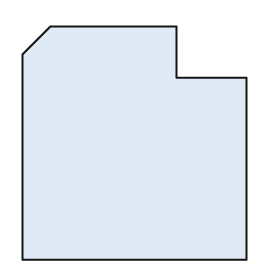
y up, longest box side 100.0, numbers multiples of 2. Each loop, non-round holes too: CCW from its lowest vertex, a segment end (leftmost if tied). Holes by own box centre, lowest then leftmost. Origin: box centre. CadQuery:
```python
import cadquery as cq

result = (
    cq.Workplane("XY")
    .moveTo(-48.0, -50.0)
    .lineTo(48.0, -50.0)
    .lineTo(48.0, 28.0)
    .lineTo(18.0, 28.0)
    .lineTo(18.0, 50.0)
    .lineTo(-36.0, 50.0)
    .lineTo(-48.0, 38.0)
    .close()
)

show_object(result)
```